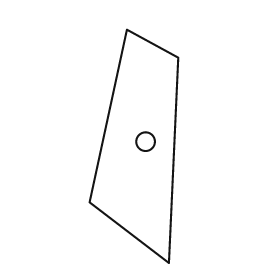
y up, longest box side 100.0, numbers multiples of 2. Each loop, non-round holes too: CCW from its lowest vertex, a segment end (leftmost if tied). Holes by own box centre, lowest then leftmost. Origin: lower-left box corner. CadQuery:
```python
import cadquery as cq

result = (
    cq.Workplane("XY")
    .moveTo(34.0, 0.0)
    .lineTo(38.0, 88.0)
    .lineTo(16.0, 100.0)
    .lineTo(0.0, 26.0)
    .close()
    .moveTo(24.0, 52.0)
    .circle(4.0)
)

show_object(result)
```